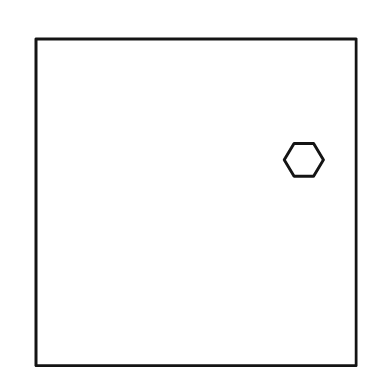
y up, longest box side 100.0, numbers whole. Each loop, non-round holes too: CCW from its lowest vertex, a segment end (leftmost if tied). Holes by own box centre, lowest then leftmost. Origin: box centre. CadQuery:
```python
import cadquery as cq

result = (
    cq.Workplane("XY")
    .moveTo(-49.0, -50.0)
    .lineTo(49.0, -50.0)
    .lineTo(49.0, 50.0)
    .lineTo(-49.0, 50.0)
    .close()
    .moveTo(30.0, 8.0)
    .lineTo(36.0, 8.0)
    .lineTo(39.0, 13.0)
    .lineTo(36.0, 18.0)
    .lineTo(30.0, 18.0)
    .lineTo(27.0, 13.0)
    .close()
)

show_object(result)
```